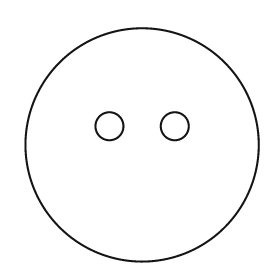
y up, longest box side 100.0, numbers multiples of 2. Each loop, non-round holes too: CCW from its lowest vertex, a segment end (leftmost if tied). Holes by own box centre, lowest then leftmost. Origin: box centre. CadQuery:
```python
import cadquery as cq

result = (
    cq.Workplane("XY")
    .moveTo(0.0, 0.0)
    .circle(50.0)
    .moveTo(-14.0, 8.0)
    .circle(6.0)
    .moveTo(14.0, 8.0)
    .circle(6.0)
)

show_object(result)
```